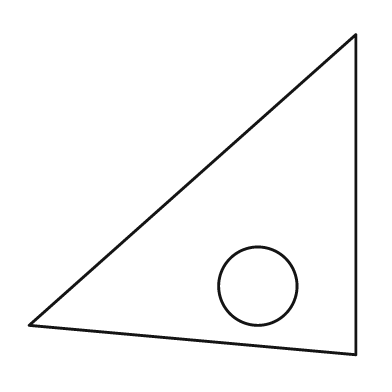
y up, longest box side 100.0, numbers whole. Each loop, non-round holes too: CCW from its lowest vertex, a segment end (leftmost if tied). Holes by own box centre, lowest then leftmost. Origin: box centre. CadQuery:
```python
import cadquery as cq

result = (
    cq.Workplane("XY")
    .moveTo(50.0, -49.0)
    .lineTo(50.0, 49.0)
    .lineTo(-50.0, -40.0)
    .close()
    .moveTo(20.0, -28.0)
    .circle(12.0)
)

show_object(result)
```